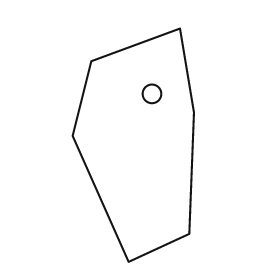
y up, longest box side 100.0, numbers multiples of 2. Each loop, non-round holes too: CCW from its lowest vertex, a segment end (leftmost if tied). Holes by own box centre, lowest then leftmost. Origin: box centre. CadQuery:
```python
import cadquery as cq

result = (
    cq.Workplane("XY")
    .moveTo(-2.0, -50.0)
    .lineTo(24.0, -38.0)
    .lineTo(26.0, 14.0)
    .lineTo(20.0, 50.0)
    .lineTo(-18.0, 36.0)
    .lineTo(-26.0, 4.0)
    .close()
    .moveTo(8.0, 22.0)
    .circle(4.0)
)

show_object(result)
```